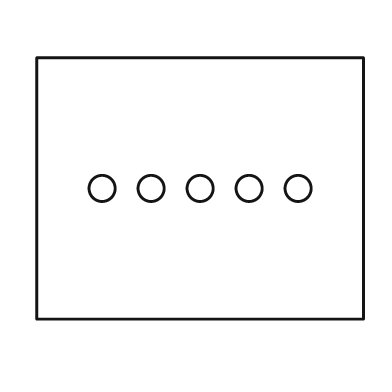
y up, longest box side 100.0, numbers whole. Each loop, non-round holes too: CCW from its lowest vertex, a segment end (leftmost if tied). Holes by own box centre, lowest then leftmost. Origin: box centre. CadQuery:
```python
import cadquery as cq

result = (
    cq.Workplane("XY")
    .moveTo(-50.0, -40.0)
    .lineTo(50.0, -40.0)
    .lineTo(50.0, 40.0)
    .lineTo(-50.0, 40.0)
    .close()
    .moveTo(-30.0, 0.0)
    .circle(4.0)
    .moveTo(-15.0, 0.0)
    .circle(4.0)
    .moveTo(0.0, 0.0)
    .circle(4.0)
    .moveTo(15.0, 0.0)
    .circle(4.0)
    .moveTo(30.0, 0.0)
    .circle(4.0)
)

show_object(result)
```